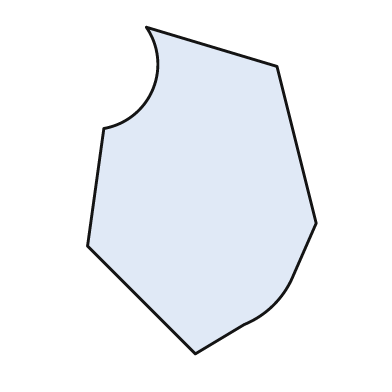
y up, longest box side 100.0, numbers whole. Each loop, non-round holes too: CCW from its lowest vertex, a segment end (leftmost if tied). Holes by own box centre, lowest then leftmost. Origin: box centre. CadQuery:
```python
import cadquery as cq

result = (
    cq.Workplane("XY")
    .moveTo(-2.0, -50.0)
    .lineTo(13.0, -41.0)
    .threePointArc((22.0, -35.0), (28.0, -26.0))
    .lineTo(35.0, -10.0)
    .lineTo(23.0, 38.0)
    .lineTo(-17.0, 50.0)
    .threePointArc((-15.0, 31.0), (-30.0, 19.0))
    .lineTo(-35.0, -17.0)
    .close()
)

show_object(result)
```